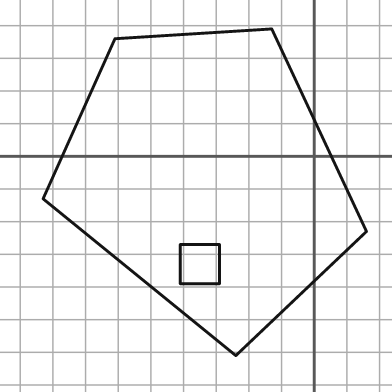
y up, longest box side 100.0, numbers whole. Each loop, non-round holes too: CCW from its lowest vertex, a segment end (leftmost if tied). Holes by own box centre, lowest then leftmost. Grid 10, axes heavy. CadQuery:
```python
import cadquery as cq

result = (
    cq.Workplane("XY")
    .moveTo(-24.0, -61.0)
    .lineTo(16.0, -23.0)
    .lineTo(-13.0, 39.0)
    .lineTo(-61.0, 36.0)
    .lineTo(-83.0, -13.0)
    .close()
    .moveTo(-41.0, -39.0)
    .lineTo(-29.0, -39.0)
    .lineTo(-29.0, -27.0)
    .lineTo(-41.0, -27.0)
    .close()
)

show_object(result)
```